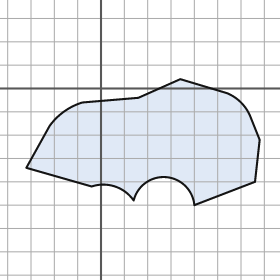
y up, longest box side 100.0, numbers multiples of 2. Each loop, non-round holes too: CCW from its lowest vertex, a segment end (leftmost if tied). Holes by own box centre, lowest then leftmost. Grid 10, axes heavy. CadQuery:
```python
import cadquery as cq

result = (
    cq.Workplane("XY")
    .moveTo(40.0, -50.0)
    .lineTo(66.0, -40.0)
    .lineTo(68.0, -22.0)
    .lineTo(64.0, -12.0)
    .threePointArc((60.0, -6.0), (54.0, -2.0))
    .lineTo(34.0, 4.0)
    .lineTo(16.0, -4.0)
    .lineTo(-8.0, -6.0)
    .threePointArc((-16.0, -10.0), (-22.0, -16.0))
    .lineTo(-32.0, -34.0)
    .lineTo(-4.0, -42.0)
    .threePointArc((6.0, -42.0), (14.0, -48.0))
    .threePointArc((28.0, -38.0), (40.0, -50.0))
    .close()
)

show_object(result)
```